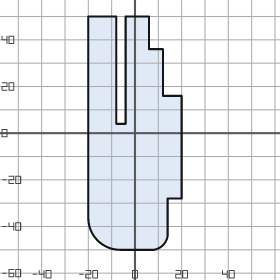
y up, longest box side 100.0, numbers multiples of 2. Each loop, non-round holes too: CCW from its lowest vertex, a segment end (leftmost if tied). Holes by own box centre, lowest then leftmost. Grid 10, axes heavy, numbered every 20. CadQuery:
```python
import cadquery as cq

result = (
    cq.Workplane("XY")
    .moveTo(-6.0, -50.0)
    .lineTo(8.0, -50.0)
    .threePointArc((12.0, -48.0), (14.0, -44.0))
    .lineTo(14.0, -28.0)
    .lineTo(20.0, -28.0)
    .lineTo(20.0, 16.0)
    .lineTo(12.0, 16.0)
    .lineTo(12.0, 36.0)
    .lineTo(6.0, 36.0)
    .lineTo(6.0, 50.0)
    .lineTo(-4.0, 50.0)
    .lineTo(-4.0, 4.0)
    .lineTo(-8.0, 4.0)
    .lineTo(-8.0, 50.0)
    .lineTo(-20.0, 50.0)
    .lineTo(-20.0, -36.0)
    .threePointArc((-16.0, -46.0), (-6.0, -50.0))
    .close()
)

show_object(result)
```